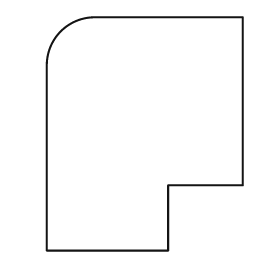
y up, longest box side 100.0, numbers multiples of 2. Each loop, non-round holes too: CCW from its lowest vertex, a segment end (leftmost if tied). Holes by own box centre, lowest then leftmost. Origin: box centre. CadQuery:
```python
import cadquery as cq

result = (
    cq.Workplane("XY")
    .moveTo(-42.0, -50.0)
    .lineTo(10.0, -50.0)
    .lineTo(10.0, -22.0)
    .lineTo(42.0, -22.0)
    .lineTo(42.0, 50.0)
    .lineTo(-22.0, 50.0)
    .threePointArc((-36.0, 44.0), (-42.0, 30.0))
    .close()
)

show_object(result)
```